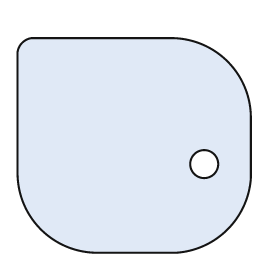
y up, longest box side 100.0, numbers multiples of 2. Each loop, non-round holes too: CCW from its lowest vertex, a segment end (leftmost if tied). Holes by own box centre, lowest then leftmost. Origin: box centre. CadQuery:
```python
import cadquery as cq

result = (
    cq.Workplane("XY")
    .moveTo(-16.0, -46.0)
    .lineTo(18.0, -46.0)
    .threePointArc((40.0, -36.0), (50.0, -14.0))
    .lineTo(50.0, 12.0)
    .threePointArc((40.0, 36.0), (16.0, 46.0))
    .lineTo(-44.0, 46.0)
    .threePointArc((-48.0, 44.0), (-50.0, 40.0))
    .lineTo(-50.0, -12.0)
    .threePointArc((-40.0, -36.0), (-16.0, -46.0))
    .close()
    .moveTo(30.0, -8.0)
    .circle(6.0)
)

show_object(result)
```